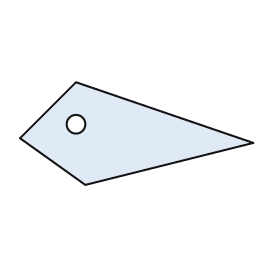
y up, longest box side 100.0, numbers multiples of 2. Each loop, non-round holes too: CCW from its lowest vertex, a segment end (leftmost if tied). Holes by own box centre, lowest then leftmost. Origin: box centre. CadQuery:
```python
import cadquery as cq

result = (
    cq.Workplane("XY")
    .moveTo(-22.0, -22.0)
    .lineTo(50.0, -4.0)
    .lineTo(-26.0, 22.0)
    .lineTo(-50.0, -2.0)
    .close()
    .moveTo(-26.0, 4.0)
    .circle(4.0)
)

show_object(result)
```